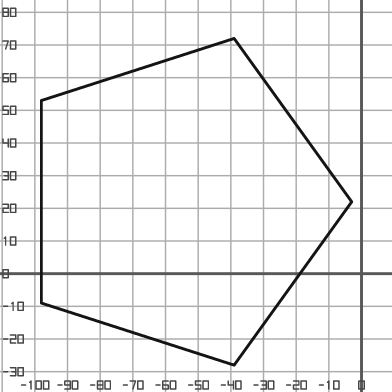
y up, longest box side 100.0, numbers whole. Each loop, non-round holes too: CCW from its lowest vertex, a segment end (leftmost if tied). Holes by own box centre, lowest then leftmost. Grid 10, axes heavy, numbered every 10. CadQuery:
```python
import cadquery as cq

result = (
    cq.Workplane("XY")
    .moveTo(-39.0, -28.0)
    .lineTo(-3.0, 22.0)
    .lineTo(-39.0, 72.0)
    .lineTo(-98.0, 53.0)
    .lineTo(-98.0, -9.0)
    .close()
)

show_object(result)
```